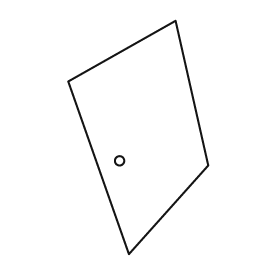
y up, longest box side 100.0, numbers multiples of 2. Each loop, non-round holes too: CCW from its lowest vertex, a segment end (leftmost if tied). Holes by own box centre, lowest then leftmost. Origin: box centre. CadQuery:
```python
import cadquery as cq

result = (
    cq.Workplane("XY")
    .moveTo(-4.0, -50.0)
    .lineTo(30.0, -12.0)
    .lineTo(16.0, 50.0)
    .lineTo(-30.0, 24.0)
    .close()
    .moveTo(-8.0, -10.0)
    .circle(2.0)
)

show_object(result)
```